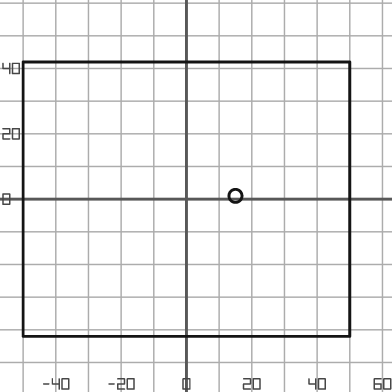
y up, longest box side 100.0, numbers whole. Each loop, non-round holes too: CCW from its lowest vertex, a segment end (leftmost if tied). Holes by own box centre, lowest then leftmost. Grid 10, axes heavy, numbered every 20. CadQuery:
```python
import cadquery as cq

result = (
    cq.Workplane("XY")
    .moveTo(-50.0, -42.0)
    .lineTo(50.0, -42.0)
    .lineTo(50.0, 42.0)
    .lineTo(-50.0, 42.0)
    .close()
    .moveTo(15.0, 1.0)
    .circle(2.0)
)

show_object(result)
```